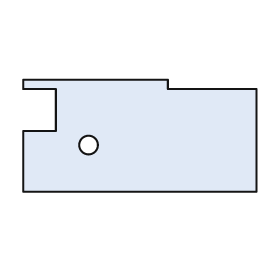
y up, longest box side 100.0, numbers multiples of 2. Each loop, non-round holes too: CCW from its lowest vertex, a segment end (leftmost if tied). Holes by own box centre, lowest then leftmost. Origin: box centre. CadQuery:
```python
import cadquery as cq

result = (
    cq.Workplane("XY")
    .moveTo(-50.0, -24.0)
    .lineTo(50.0, -24.0)
    .lineTo(50.0, 20.0)
    .lineTo(12.0, 20.0)
    .lineTo(12.0, 24.0)
    .lineTo(-50.0, 24.0)
    .lineTo(-50.0, 20.0)
    .lineTo(-36.0, 20.0)
    .lineTo(-36.0, 2.0)
    .lineTo(-50.0, 2.0)
    .close()
    .moveTo(-22.0, -4.0)
    .circle(4.0)
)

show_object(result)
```